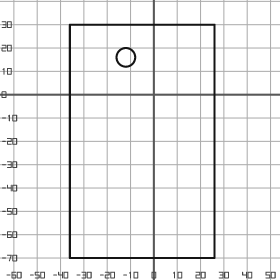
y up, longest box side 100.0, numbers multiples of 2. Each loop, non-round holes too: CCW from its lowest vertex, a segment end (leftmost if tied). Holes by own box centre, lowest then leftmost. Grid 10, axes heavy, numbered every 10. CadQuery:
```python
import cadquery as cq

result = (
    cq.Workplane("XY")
    .moveTo(-36.0, -70.0)
    .lineTo(26.0, -70.0)
    .lineTo(26.0, 30.0)
    .lineTo(-36.0, 30.0)
    .close()
    .moveTo(-12.0, 16.0)
    .circle(4.0)
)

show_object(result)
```